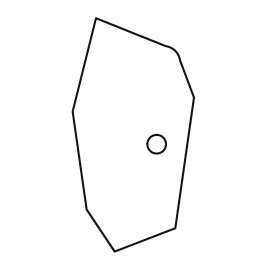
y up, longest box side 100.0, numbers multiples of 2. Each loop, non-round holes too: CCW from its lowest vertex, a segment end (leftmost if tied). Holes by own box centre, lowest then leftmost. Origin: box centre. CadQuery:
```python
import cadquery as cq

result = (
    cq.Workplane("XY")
    .moveTo(-8.0, -50.0)
    .lineTo(18.0, -40.0)
    .lineTo(26.0, 16.0)
    .lineTo(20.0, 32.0)
    .threePointArc((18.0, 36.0), (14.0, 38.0))
    .lineTo(-16.0, 50.0)
    .lineTo(-26.0, 10.0)
    .lineTo(-20.0, -32.0)
    .close()
    .moveTo(10.0, -4.0)
    .circle(4.0)
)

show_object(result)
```